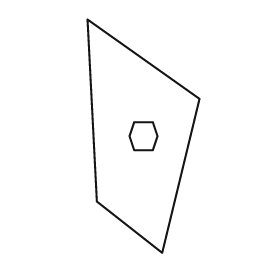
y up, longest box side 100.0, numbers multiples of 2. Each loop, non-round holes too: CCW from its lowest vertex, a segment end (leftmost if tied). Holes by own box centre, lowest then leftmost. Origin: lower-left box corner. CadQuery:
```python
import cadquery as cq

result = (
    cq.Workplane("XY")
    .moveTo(32.0, 0.0)
    .lineTo(48.0, 66.0)
    .lineTo(0.0, 100.0)
    .lineTo(4.0, 22.0)
    .close()
    .moveTo(20.0, 44.0)
    .lineTo(28.0, 44.0)
    .lineTo(30.0, 50.0)
    .lineTo(28.0, 56.0)
    .lineTo(20.0, 56.0)
    .lineTo(18.0, 50.0)
    .close()
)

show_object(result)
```